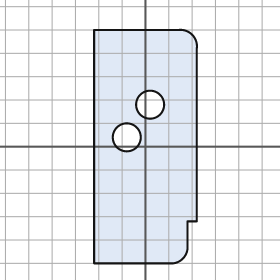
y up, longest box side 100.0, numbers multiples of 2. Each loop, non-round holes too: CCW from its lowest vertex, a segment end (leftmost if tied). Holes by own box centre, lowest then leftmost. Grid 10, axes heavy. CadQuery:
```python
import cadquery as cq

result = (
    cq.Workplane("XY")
    .moveTo(-22.0, -50.0)
    .lineTo(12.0, -50.0)
    .threePointArc((16.0, -48.0), (18.0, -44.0))
    .lineTo(18.0, -32.0)
    .lineTo(22.0, -32.0)
    .lineTo(22.0, 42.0)
    .threePointArc((20.0, 48.0), (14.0, 50.0))
    .lineTo(-22.0, 50.0)
    .close()
    .moveTo(-8.0, 4.0)
    .circle(6.0)
    .moveTo(2.0, 18.0)
    .circle(6.0)
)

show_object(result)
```